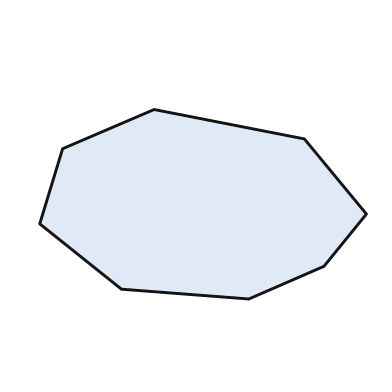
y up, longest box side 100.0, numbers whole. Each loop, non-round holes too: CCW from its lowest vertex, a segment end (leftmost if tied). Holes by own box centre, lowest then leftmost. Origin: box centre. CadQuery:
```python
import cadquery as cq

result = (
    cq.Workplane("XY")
    .moveTo(14.0, -29.0)
    .lineTo(37.0, -19.0)
    .lineTo(50.0, -3.0)
    .lineTo(31.0, 20.0)
    .lineTo(-15.0, 29.0)
    .lineTo(-43.0, 17.0)
    .lineTo(-50.0, -6.0)
    .lineTo(-25.0, -26.0)
    .close()
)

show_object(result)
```